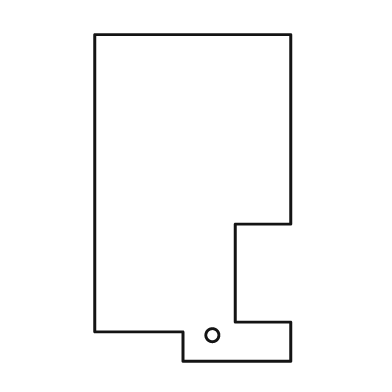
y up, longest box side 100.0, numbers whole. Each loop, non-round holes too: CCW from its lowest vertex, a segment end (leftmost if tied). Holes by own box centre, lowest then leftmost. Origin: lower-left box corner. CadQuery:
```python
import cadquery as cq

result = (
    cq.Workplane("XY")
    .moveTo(27.0, 0.0)
    .lineTo(60.0, 0.0)
    .lineTo(60.0, 12.0)
    .lineTo(43.0, 12.0)
    .lineTo(43.0, 42.0)
    .lineTo(60.0, 42.0)
    .lineTo(60.0, 100.0)
    .lineTo(0.0, 100.0)
    .lineTo(0.0, 9.0)
    .lineTo(27.0, 9.0)
    .close()
    .moveTo(36.0, 8.0)
    .circle(2.0)
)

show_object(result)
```